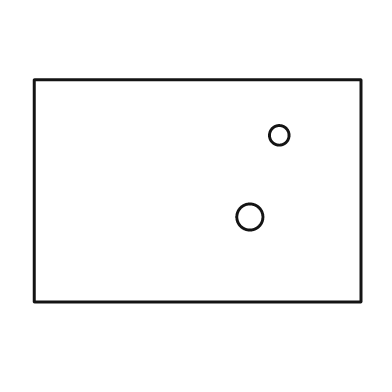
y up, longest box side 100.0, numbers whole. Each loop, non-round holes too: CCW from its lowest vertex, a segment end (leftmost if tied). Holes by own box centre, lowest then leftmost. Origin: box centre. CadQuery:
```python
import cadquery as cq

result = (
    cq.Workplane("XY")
    .moveTo(-50.0, -34.0)
    .lineTo(50.0, -34.0)
    .lineTo(50.0, 34.0)
    .lineTo(-50.0, 34.0)
    .close()
    .moveTo(16.0, -8.0)
    .circle(4.0)
    .moveTo(25.0, 17.0)
    .circle(3.0)
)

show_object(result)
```